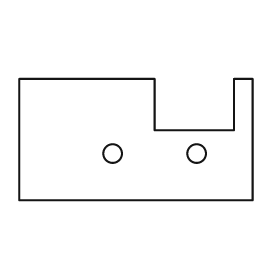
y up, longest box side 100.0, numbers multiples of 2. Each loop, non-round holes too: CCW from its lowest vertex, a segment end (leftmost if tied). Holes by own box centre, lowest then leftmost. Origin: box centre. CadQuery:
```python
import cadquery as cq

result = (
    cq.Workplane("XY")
    .moveTo(-50.0, -26.0)
    .lineTo(50.0, -26.0)
    .lineTo(50.0, 26.0)
    .lineTo(42.0, 26.0)
    .lineTo(42.0, 4.0)
    .lineTo(8.0, 4.0)
    .lineTo(8.0, 26.0)
    .lineTo(-50.0, 26.0)
    .close()
    .moveTo(-10.0, -6.0)
    .circle(4.0)
    .moveTo(26.0, -6.0)
    .circle(4.0)
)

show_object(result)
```